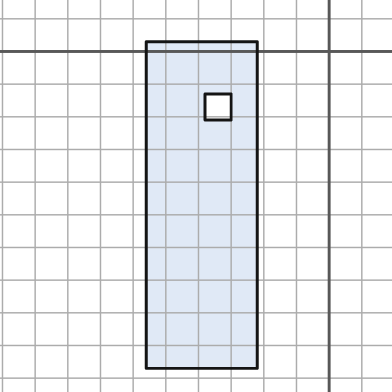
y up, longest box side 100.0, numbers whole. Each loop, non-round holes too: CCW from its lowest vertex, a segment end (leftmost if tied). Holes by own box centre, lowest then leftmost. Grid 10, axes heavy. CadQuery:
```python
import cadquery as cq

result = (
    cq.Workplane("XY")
    .moveTo(-56.0, -97.0)
    .lineTo(-22.0, -97.0)
    .lineTo(-22.0, 3.0)
    .lineTo(-56.0, 3.0)
    .close()
    .moveTo(-38.0, -21.0)
    .lineTo(-30.0, -21.0)
    .lineTo(-30.0, -13.0)
    .lineTo(-38.0, -13.0)
    .close()
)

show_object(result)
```